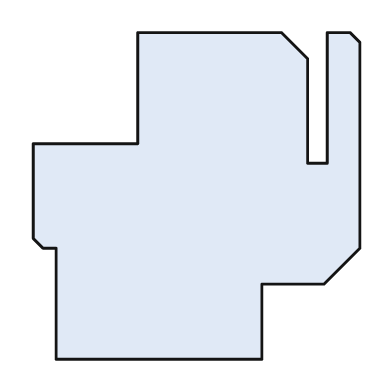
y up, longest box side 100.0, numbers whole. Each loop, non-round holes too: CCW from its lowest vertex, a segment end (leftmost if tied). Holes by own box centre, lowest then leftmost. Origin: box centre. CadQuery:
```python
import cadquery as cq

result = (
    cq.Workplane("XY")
    .moveTo(-43.0, -50.0)
    .lineTo(20.0, -50.0)
    .lineTo(20.0, -27.0)
    .lineTo(39.0, -27.0)
    .lineTo(50.0, -16.0)
    .lineTo(50.0, 47.0)
    .lineTo(47.0, 50.0)
    .lineTo(40.0, 50.0)
    .lineTo(40.0, 10.0)
    .lineTo(34.0, 10.0)
    .lineTo(34.0, 42.0)
    .lineTo(26.0, 50.0)
    .lineTo(-18.0, 50.0)
    .lineTo(-18.0, 16.0)
    .lineTo(-50.0, 16.0)
    .lineTo(-50.0, -13.0)
    .lineTo(-47.0, -16.0)
    .lineTo(-43.0, -16.0)
    .close()
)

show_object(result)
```